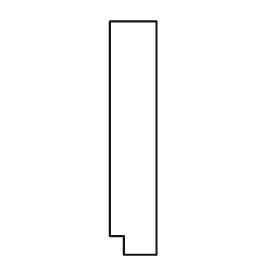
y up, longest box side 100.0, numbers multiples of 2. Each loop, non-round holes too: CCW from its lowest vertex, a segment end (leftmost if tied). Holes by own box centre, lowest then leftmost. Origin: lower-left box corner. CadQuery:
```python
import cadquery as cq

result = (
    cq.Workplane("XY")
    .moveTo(6.0, 0.0)
    .lineTo(20.0, 0.0)
    .lineTo(20.0, 100.0)
    .lineTo(0.0, 100.0)
    .lineTo(0.0, 8.0)
    .lineTo(6.0, 8.0)
    .close()
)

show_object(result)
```